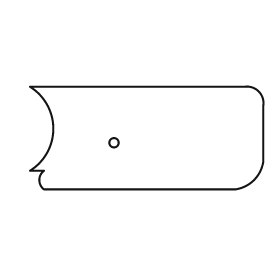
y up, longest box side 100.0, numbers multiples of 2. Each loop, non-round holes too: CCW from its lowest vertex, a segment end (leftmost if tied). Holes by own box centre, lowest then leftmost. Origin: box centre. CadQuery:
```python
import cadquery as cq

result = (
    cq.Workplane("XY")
    .moveTo(-44.0, -22.0)
    .lineTo(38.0, -22.0)
    .threePointArc((46.0, -18.0), (50.0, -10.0))
    .lineTo(50.0, 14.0)
    .threePointArc((48.0, 20.0), (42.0, 22.0))
    .lineTo(-50.0, 22.0)
    .threePointArc((-40.0, 4.0), (-50.0, -14.0))
    .lineTo(-44.0, -14.0)
    .threePointArc((-46.0, -18.0), (-44.0, -22.0))
    .close()
    .moveTo(-14.0, -2.0)
    .circle(2.0)
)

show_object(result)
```